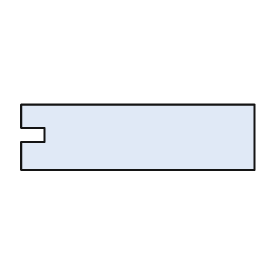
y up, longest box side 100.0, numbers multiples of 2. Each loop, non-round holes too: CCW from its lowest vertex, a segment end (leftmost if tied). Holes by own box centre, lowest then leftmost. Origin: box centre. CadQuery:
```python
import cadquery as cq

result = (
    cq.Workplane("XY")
    .moveTo(-50.0, -14.0)
    .lineTo(50.0, -14.0)
    .lineTo(50.0, 14.0)
    .lineTo(-50.0, 14.0)
    .lineTo(-50.0, 4.0)
    .lineTo(-40.0, 4.0)
    .lineTo(-40.0, -2.0)
    .lineTo(-50.0, -2.0)
    .close()
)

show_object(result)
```